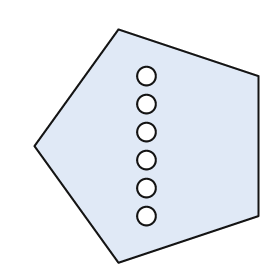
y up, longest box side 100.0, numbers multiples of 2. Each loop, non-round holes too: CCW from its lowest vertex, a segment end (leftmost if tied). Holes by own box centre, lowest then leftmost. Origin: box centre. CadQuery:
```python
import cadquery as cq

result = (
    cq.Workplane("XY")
    .moveTo(-12.0, -50.0)
    .lineTo(48.0, -30.0)
    .lineTo(48.0, 30.0)
    .lineTo(-12.0, 50.0)
    .lineTo(-48.0, 0.0)
    .close()
    .moveTo(0.0, -30.0)
    .circle(4.0)
    .moveTo(0.0, -18.0)
    .circle(4.0)
    .moveTo(0.0, -6.0)
    .circle(4.0)
    .moveTo(0.0, 6.0)
    .circle(4.0)
    .moveTo(0.0, 18.0)
    .circle(4.0)
    .moveTo(0.0, 30.0)
    .circle(4.0)
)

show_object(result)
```